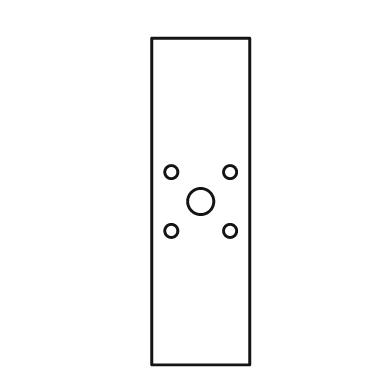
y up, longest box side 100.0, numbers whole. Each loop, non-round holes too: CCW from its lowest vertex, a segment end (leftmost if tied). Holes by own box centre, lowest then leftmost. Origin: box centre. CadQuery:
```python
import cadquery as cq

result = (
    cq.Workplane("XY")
    .moveTo(-15.0, -50.0)
    .lineTo(15.0, -50.0)
    .lineTo(15.0, 50.0)
    .lineTo(-15.0, 50.0)
    .close()
    .moveTo(-9.0, -9.0)
    .circle(2.0)
    .moveTo(9.0, -9.0)
    .circle(2.0)
    .moveTo(0.0, 0.0)
    .circle(4.0)
    .moveTo(-9.0, 9.0)
    .circle(2.0)
    .moveTo(9.0, 9.0)
    .circle(2.0)
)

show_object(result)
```